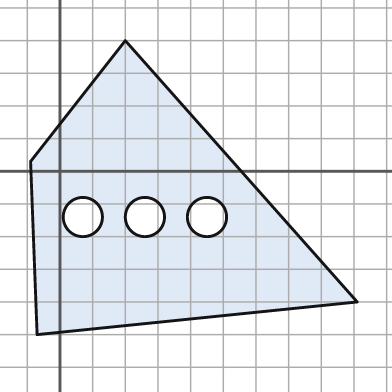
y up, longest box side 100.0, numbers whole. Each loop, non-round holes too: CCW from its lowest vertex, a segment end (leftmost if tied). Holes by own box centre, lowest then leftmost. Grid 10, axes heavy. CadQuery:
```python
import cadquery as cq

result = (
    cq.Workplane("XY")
    .moveTo(-7.0, -50.0)
    .lineTo(91.0, -40.0)
    .lineTo(20.0, 40.0)
    .lineTo(-9.0, 3.0)
    .close()
    .moveTo(7.0, -14.0)
    .circle(6.0)
    .moveTo(26.0, -14.0)
    .circle(6.0)
    .moveTo(45.0, -14.0)
    .circle(6.0)
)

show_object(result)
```